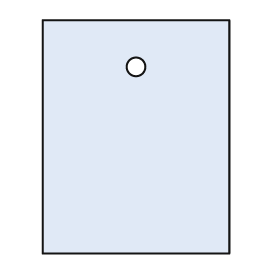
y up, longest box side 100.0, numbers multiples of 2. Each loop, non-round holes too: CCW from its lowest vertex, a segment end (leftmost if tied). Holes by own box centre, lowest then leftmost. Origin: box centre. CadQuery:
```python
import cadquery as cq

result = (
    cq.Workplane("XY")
    .moveTo(-40.0, -50.0)
    .lineTo(40.0, -50.0)
    .lineTo(40.0, 50.0)
    .lineTo(-40.0, 50.0)
    .close()
    .moveTo(0.0, 30.0)
    .circle(4.0)
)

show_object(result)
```